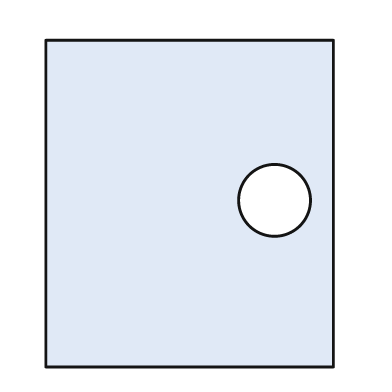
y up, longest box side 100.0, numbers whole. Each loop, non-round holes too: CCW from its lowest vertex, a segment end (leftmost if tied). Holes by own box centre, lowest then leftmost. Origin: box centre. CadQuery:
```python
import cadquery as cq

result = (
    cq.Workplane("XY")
    .moveTo(-44.0, -50.0)
    .lineTo(44.0, -50.0)
    .lineTo(44.0, 50.0)
    .lineTo(-44.0, 50.0)
    .close()
    .moveTo(26.0, 1.0)
    .circle(11.0)
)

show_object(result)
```